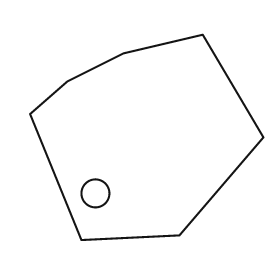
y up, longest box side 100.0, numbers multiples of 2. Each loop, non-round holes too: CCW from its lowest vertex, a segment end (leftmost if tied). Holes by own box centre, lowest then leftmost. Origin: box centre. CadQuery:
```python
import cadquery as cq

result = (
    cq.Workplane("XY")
    .moveTo(-28.0, -44.0)
    .lineTo(14.0, -42.0)
    .lineTo(50.0, 0.0)
    .lineTo(24.0, 44.0)
    .lineTo(-10.0, 36.0)
    .lineTo(-34.0, 24.0)
    .lineTo(-50.0, 10.0)
    .close()
    .moveTo(-22.0, -24.0)
    .circle(6.0)
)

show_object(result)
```